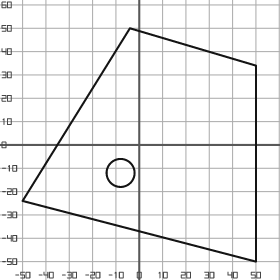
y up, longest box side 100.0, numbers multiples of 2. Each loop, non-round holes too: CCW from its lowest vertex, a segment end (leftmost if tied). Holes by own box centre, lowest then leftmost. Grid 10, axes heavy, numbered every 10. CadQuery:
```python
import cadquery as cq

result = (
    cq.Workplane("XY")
    .moveTo(50.0, -50.0)
    .lineTo(50.0, 34.0)
    .lineTo(-4.0, 50.0)
    .lineTo(-50.0, -24.0)
    .close()
    .moveTo(-8.0, -12.0)
    .circle(6.0)
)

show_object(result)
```